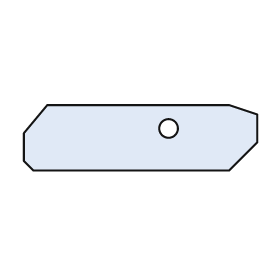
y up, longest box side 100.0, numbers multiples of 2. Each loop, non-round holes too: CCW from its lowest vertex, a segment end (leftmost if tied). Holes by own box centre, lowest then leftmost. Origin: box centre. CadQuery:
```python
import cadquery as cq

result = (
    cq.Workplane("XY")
    .moveTo(-46.0, -14.0)
    .lineTo(38.0, -14.0)
    .lineTo(50.0, -2.0)
    .lineTo(50.0, 10.0)
    .lineTo(38.0, 14.0)
    .lineTo(-40.0, 14.0)
    .lineTo(-50.0, 2.0)
    .lineTo(-50.0, -10.0)
    .close()
    .moveTo(12.0, 4.0)
    .circle(4.0)
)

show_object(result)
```